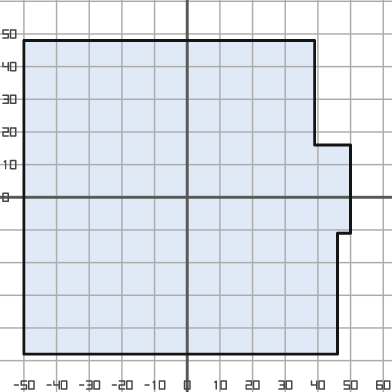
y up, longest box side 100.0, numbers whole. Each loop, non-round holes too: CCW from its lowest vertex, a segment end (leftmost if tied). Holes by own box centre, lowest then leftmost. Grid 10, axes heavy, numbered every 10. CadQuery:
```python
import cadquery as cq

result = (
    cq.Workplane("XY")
    .moveTo(-50.0, -48.0)
    .lineTo(46.0, -48.0)
    .lineTo(46.0, -11.0)
    .lineTo(50.0, -11.0)
    .lineTo(50.0, 16.0)
    .lineTo(39.0, 16.0)
    .lineTo(39.0, 48.0)
    .lineTo(-50.0, 48.0)
    .close()
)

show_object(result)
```